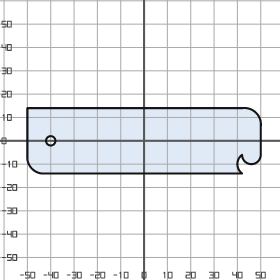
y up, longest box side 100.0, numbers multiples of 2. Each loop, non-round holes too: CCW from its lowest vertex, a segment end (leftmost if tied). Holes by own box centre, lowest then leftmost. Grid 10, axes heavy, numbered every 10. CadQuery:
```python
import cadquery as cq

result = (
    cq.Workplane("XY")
    .moveTo(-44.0, -14.0)
    .lineTo(42.0, -14.0)
    .threePointArc((40.0, -10.0), (42.0, -6.0))
    .threePointArc((46.0, -10.0), (50.0, -6.0))
    .lineTo(50.0, 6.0)
    .threePointArc((48.0, 12.0), (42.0, 14.0))
    .lineTo(-50.0, 14.0)
    .lineTo(-50.0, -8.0)
    .threePointArc((-48.0, -12.0), (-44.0, -14.0))
    .close()
    .moveTo(-40.0, 0.0)
    .circle(2.0)
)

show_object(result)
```